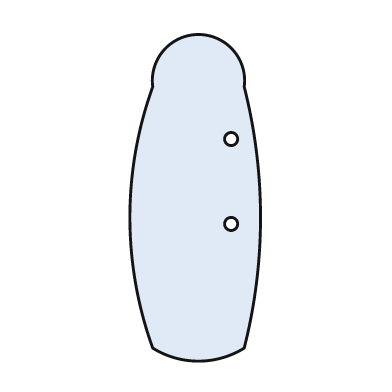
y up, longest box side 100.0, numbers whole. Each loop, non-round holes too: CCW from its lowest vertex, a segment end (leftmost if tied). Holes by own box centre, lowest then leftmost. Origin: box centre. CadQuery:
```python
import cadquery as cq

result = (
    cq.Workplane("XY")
    .moveTo(-13.0, -46.0)
    .threePointArc((1.0, -50.0), (15.0, -46.0))
    .threePointArc((20.0, -6.0), (15.0, 34.0))
    .threePointArc((1.0, 50.0), (-13.0, 34.0))
    .threePointArc((-20.0, -6.0), (-13.0, -46.0))
    .close()
    .moveTo(11.0, -8.0)
    .circle(2.0)
    .moveTo(11.0, 18.0)
    .circle(2.0)
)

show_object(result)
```